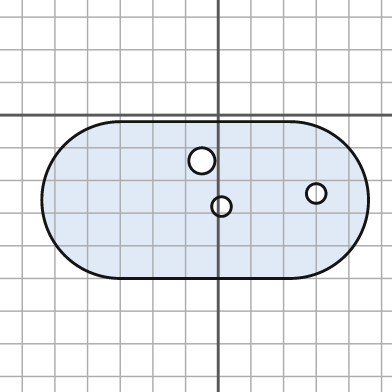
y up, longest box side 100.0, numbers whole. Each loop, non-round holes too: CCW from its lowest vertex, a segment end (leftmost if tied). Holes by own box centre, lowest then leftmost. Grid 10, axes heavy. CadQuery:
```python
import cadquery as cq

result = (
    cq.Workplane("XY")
    .moveTo(-30.0, -50.0)
    .lineTo(22.0, -50.0)
    .threePointArc((46.0, -26.0), (22.0, -2.0))
    .lineTo(-30.0, -2.0)
    .threePointArc((-54.0, -26.0), (-30.0, -50.0))
    .close()
    .moveTo(1.0, -28.0)
    .circle(3.0)
    .moveTo(30.0, -24.0)
    .circle(3.0)
    .moveTo(-5.0, -14.0)
    .circle(4.0)
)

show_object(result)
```